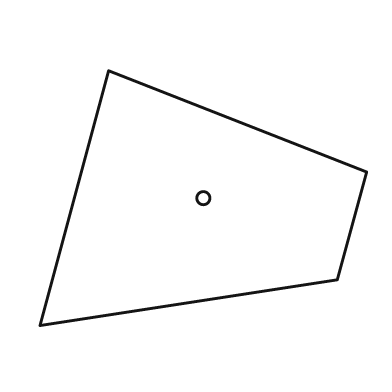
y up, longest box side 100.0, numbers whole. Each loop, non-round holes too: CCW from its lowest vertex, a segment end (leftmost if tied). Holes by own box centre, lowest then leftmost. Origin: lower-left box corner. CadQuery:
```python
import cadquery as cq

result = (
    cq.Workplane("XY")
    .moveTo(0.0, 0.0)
    .lineTo(91.0, 14.0)
    .lineTo(100.0, 47.0)
    .lineTo(21.0, 78.0)
    .close()
    .moveTo(50.0, 39.0)
    .circle(2.0)
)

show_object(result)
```